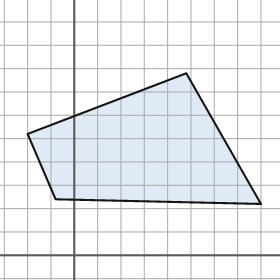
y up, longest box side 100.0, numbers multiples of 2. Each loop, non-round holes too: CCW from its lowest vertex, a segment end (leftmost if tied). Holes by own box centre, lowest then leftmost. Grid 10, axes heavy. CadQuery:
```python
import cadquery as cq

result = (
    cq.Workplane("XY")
    .moveTo(80.0, 22.0)
    .lineTo(48.0, 78.0)
    .lineTo(-20.0, 52.0)
    .lineTo(-8.0, 24.0)
    .close()
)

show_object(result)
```